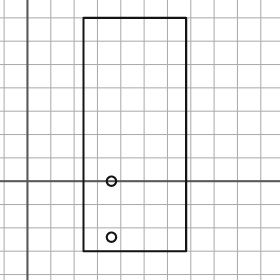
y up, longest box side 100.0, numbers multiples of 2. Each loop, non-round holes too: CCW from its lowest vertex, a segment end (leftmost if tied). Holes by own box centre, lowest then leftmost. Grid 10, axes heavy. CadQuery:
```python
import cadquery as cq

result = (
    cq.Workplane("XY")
    .moveTo(24.0, -30.0)
    .lineTo(68.0, -30.0)
    .lineTo(68.0, 70.0)
    .lineTo(24.0, 70.0)
    .close()
    .moveTo(36.0, -24.0)
    .circle(2.0)
    .moveTo(36.0, 0.0)
    .circle(2.0)
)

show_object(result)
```